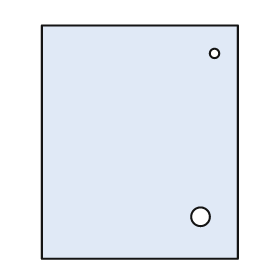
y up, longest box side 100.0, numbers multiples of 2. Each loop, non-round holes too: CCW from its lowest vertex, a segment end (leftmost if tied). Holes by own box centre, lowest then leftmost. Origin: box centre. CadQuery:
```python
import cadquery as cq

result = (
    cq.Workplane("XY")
    .moveTo(-42.0, -50.0)
    .lineTo(42.0, -50.0)
    .lineTo(42.0, 50.0)
    .lineTo(-42.0, 50.0)
    .close()
    .moveTo(26.0, -32.0)
    .circle(4.0)
    .moveTo(32.0, 38.0)
    .circle(2.0)
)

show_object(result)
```